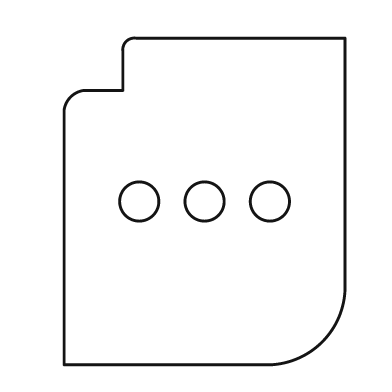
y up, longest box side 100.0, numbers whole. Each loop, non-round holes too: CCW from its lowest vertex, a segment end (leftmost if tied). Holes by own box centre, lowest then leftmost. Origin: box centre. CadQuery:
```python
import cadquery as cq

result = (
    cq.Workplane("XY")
    .moveTo(-43.0, -50.0)
    .lineTo(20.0, -50.0)
    .threePointArc((36.0, -43.0), (43.0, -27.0))
    .lineTo(43.0, 50.0)
    .lineTo(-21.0, 50.0)
    .threePointArc((-24.0, 49.0), (-25.0, 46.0))
    .lineTo(-25.0, 34.0)
    .lineTo(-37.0, 34.0)
    .threePointArc((-41.0, 32.0), (-43.0, 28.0))
    .close()
    .moveTo(-20.0, 0.0)
    .circle(6.0)
    .moveTo(0.0, 0.0)
    .circle(6.0)
    .moveTo(20.0, 0.0)
    .circle(6.0)
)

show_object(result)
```